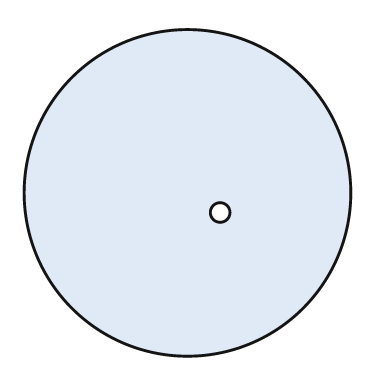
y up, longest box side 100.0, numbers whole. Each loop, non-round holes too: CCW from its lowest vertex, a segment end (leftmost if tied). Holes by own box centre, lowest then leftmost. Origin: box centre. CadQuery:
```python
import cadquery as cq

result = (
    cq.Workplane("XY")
    .moveTo(0.0, 0.0)
    .circle(50.0)
    .moveTo(10.0, -6.0)
    .circle(3.0)
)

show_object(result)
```